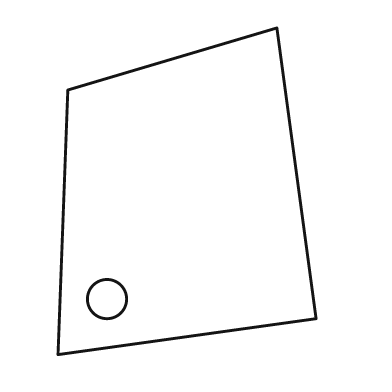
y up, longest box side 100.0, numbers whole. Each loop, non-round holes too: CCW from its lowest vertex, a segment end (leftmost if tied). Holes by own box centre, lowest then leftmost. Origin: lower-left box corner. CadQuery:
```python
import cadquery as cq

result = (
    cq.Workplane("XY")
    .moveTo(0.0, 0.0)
    .lineTo(79.0, 11.0)
    .lineTo(67.0, 100.0)
    .lineTo(3.0, 81.0)
    .close()
    .moveTo(15.0, 17.0)
    .circle(6.0)
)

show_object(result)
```